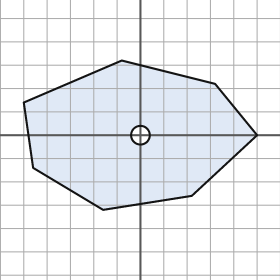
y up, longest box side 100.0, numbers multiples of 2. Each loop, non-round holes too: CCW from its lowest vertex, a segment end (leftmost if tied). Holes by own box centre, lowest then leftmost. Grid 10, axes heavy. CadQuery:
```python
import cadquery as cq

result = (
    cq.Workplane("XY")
    .moveTo(-16.0, -32.0)
    .lineTo(22.0, -26.0)
    .lineTo(50.0, 0.0)
    .lineTo(32.0, 22.0)
    .lineTo(-8.0, 32.0)
    .lineTo(-50.0, 14.0)
    .lineTo(-46.0, -14.0)
    .close()
    .moveTo(0.0, 0.0)
    .circle(4.0)
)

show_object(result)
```